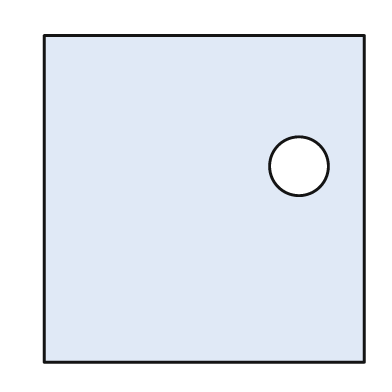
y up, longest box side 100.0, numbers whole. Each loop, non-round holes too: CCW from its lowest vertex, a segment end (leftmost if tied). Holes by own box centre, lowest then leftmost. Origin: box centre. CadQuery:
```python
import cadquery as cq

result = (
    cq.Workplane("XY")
    .moveTo(-49.0, -50.0)
    .lineTo(49.0, -50.0)
    .lineTo(49.0, 50.0)
    .lineTo(-49.0, 50.0)
    .close()
    .moveTo(29.0, 10.0)
    .circle(9.0)
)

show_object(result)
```